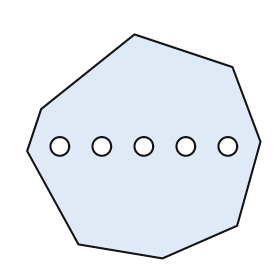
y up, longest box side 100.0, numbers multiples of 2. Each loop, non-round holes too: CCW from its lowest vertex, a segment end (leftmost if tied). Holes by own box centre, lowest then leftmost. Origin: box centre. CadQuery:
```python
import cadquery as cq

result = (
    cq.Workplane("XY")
    .moveTo(8.0, -48.0)
    .lineTo(40.0, -34.0)
    .lineTo(50.0, 2.0)
    .lineTo(38.0, 34.0)
    .lineTo(-4.0, 48.0)
    .lineTo(-44.0, 16.0)
    .lineTo(-50.0, -2.0)
    .lineTo(-28.0, -42.0)
    .close()
    .moveTo(-36.0, 0.0)
    .circle(4.0)
    .moveTo(-18.0, 0.0)
    .circle(4.0)
    .moveTo(0.0, 0.0)
    .circle(4.0)
    .moveTo(18.0, 0.0)
    .circle(4.0)
    .moveTo(36.0, 0.0)
    .circle(4.0)
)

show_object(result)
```